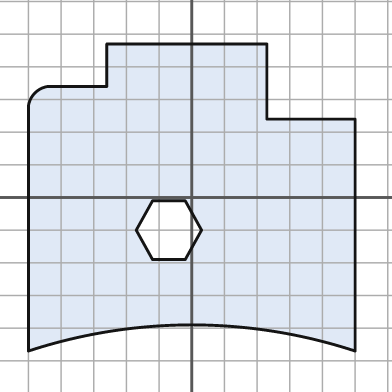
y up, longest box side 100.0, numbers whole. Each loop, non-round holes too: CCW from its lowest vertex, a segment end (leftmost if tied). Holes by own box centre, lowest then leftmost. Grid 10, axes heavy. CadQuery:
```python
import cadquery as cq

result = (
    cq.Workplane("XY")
    .moveTo(-50.0, -47.0)
    .threePointArc((0.0, -39.0), (50.0, -47.0))
    .lineTo(50.0, 24.0)
    .lineTo(23.0, 24.0)
    .lineTo(23.0, 47.0)
    .lineTo(-26.0, 47.0)
    .lineTo(-26.0, 34.0)
    .lineTo(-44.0, 34.0)
    .threePointArc((-48.0, 32.0), (-50.0, 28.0))
    .close()
    .moveTo(-12.0, -19.0)
    .lineTo(-2.0, -19.0)
    .lineTo(3.0, -10.0)
    .lineTo(-2.0, -1.0)
    .lineTo(-12.0, -1.0)
    .lineTo(-17.0, -10.0)
    .close()
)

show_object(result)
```